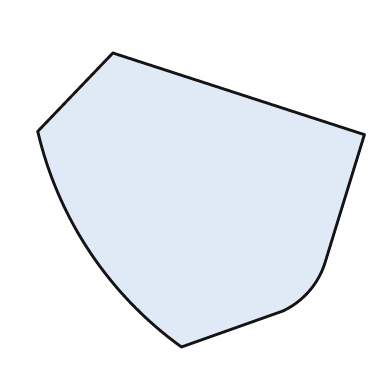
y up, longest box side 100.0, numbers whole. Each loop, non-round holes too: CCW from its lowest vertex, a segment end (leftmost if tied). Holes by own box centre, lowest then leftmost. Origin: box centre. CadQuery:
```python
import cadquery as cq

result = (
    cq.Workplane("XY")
    .moveTo(-6.0, -45.0)
    .lineTo(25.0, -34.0)
    .threePointArc((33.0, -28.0), (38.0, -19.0))
    .lineTo(50.0, 20.0)
    .lineTo(-27.0, 45.0)
    .lineTo(-50.0, 21.0)
    .threePointArc((-34.0, -16.0), (-6.0, -45.0))
    .close()
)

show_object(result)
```